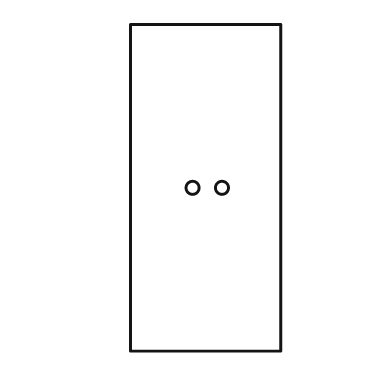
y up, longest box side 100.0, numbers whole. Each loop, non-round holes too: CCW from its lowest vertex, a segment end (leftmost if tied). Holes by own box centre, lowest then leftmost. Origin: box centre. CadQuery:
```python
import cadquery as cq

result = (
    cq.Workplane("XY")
    .moveTo(-23.0, -50.0)
    .lineTo(23.0, -50.0)
    .lineTo(23.0, 50.0)
    .lineTo(-23.0, 50.0)
    .close()
    .moveTo(-4.0, 0.0)
    .circle(2.0)
    .moveTo(5.0, 0.0)
    .circle(2.0)
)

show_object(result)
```